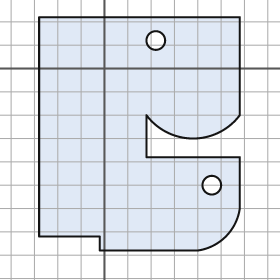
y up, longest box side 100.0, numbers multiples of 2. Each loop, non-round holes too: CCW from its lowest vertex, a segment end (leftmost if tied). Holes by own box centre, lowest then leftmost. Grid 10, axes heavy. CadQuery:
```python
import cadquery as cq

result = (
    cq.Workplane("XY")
    .moveTo(-2.0, -78.0)
    .lineTo(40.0, -78.0)
    .threePointArc((52.0, -72.0), (58.0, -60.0))
    .lineTo(58.0, -38.0)
    .lineTo(18.0, -38.0)
    .lineTo(18.0, -20.0)
    .threePointArc((38.0, -30.0), (58.0, -20.0))
    .lineTo(58.0, 22.0)
    .lineTo(-28.0, 22.0)
    .lineTo(-28.0, -72.0)
    .lineTo(-2.0, -72.0)
    .close()
    .moveTo(46.0, -50.0)
    .circle(4.0)
    .moveTo(22.0, 12.0)
    .circle(4.0)
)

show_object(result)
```